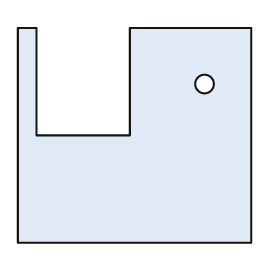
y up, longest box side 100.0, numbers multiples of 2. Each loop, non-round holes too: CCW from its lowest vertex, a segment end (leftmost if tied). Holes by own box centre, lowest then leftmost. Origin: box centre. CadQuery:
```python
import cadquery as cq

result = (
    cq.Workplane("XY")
    .moveTo(-50.0, -46.0)
    .lineTo(50.0, -46.0)
    .lineTo(50.0, 46.0)
    .lineTo(-2.0, 46.0)
    .lineTo(-2.0, 0.0)
    .lineTo(-42.0, 0.0)
    .lineTo(-42.0, 46.0)
    .lineTo(-50.0, 46.0)
    .close()
    .moveTo(30.0, 22.0)
    .circle(4.0)
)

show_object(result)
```